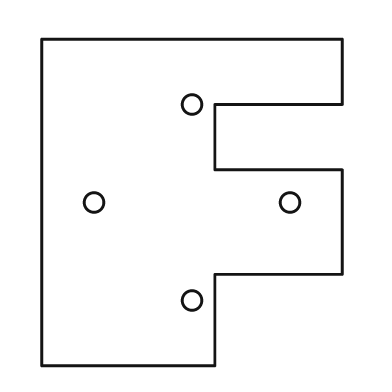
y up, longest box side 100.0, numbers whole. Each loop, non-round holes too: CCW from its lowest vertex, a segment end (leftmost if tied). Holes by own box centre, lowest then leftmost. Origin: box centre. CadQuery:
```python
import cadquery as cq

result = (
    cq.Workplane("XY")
    .moveTo(-46.0, -50.0)
    .lineTo(7.0, -50.0)
    .lineTo(7.0, -22.0)
    .lineTo(46.0, -22.0)
    .lineTo(46.0, 10.0)
    .lineTo(7.0, 10.0)
    .lineTo(7.0, 30.0)
    .lineTo(46.0, 30.0)
    .lineTo(46.0, 50.0)
    .lineTo(-46.0, 50.0)
    .close()
    .moveTo(0.0, -30.0)
    .circle(3.0)
    .moveTo(-30.0, 0.0)
    .circle(3.0)
    .moveTo(30.0, 0.0)
    .circle(3.0)
    .moveTo(0.0, 30.0)
    .circle(3.0)
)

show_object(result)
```